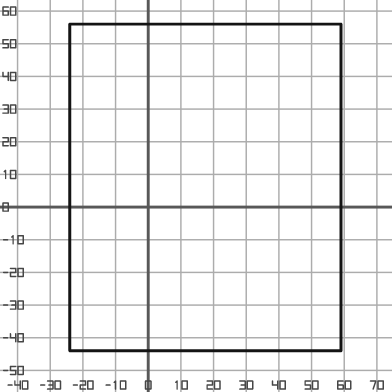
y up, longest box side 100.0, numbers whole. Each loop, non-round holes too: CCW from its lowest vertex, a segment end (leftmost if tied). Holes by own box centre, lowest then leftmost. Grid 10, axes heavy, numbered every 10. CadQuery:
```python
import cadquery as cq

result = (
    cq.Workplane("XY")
    .moveTo(-24.0, -44.0)
    .lineTo(59.0, -44.0)
    .lineTo(59.0, 56.0)
    .lineTo(-24.0, 56.0)
    .close()
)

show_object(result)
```